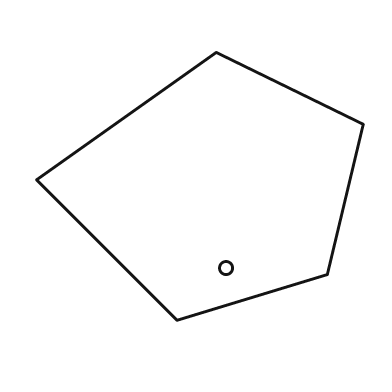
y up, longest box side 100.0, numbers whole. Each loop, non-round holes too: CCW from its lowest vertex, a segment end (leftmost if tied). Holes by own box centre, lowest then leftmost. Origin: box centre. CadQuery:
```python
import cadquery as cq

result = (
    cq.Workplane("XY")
    .moveTo(-7.0, -41.0)
    .lineTo(39.0, -27.0)
    .lineTo(50.0, 19.0)
    .lineTo(5.0, 41.0)
    .lineTo(-50.0, 2.0)
    .close()
    .moveTo(8.0, -25.0)
    .circle(2.0)
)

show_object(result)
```